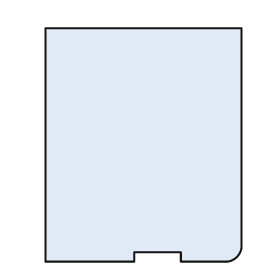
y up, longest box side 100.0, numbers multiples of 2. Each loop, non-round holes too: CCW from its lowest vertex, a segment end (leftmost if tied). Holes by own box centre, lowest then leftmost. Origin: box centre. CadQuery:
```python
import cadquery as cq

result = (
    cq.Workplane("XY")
    .moveTo(-42.0, -50.0)
    .lineTo(-4.0, -50.0)
    .lineTo(-4.0, -46.0)
    .lineTo(16.0, -46.0)
    .lineTo(16.0, -50.0)
    .lineTo(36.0, -50.0)
    .threePointArc((40.0, -48.0), (42.0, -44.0))
    .lineTo(42.0, 50.0)
    .lineTo(-42.0, 50.0)
    .close()
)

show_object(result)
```